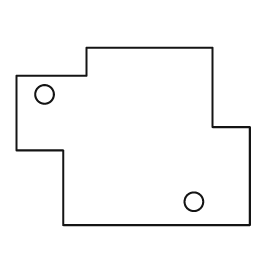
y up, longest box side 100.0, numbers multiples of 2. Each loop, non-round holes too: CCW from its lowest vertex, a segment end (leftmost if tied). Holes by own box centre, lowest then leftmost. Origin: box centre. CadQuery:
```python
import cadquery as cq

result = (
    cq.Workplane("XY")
    .moveTo(-30.0, -38.0)
    .lineTo(50.0, -38.0)
    .lineTo(50.0, 4.0)
    .lineTo(34.0, 4.0)
    .lineTo(34.0, 38.0)
    .lineTo(-20.0, 38.0)
    .lineTo(-20.0, 26.0)
    .lineTo(-50.0, 26.0)
    .lineTo(-50.0, -6.0)
    .lineTo(-30.0, -6.0)
    .close()
    .moveTo(26.0, -28.0)
    .circle(4.0)
    .moveTo(-38.0, 18.0)
    .circle(4.0)
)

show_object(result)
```